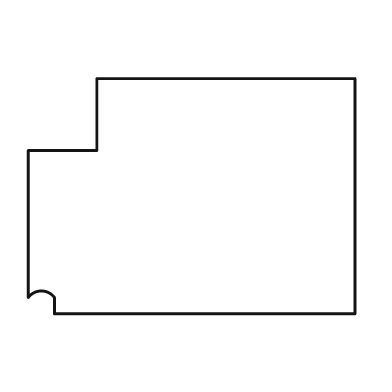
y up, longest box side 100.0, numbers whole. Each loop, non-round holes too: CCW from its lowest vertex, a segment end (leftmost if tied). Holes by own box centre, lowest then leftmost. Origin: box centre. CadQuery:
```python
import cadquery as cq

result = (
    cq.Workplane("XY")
    .moveTo(-42.0, -36.0)
    .lineTo(50.0, -36.0)
    .lineTo(50.0, 36.0)
    .lineTo(-29.0, 36.0)
    .lineTo(-29.0, 14.0)
    .lineTo(-50.0, 14.0)
    .lineTo(-50.0, -31.0)
    .threePointArc((-46.0, -29.0), (-42.0, -31.0))
    .close()
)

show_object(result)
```